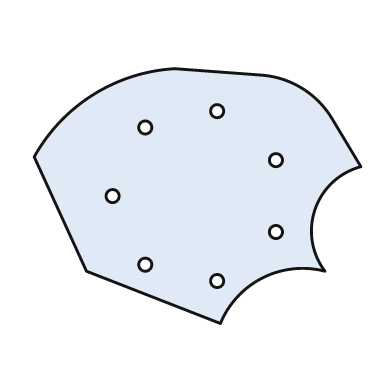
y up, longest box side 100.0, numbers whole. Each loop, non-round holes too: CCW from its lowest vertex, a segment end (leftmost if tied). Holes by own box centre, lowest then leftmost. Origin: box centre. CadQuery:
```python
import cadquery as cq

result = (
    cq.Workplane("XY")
    .moveTo(7.0, -39.0)
    .threePointArc((20.0, -25.0), (39.0, -23.0))
    .threePointArc((36.0, -4.0), (50.0, 9.0))
    .lineTo(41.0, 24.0)
    .threePointArc((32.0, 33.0), (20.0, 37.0))
    .lineTo(-7.0, 39.0)
    .threePointArc((-32.0, 31.0), (-50.0, 12.0))
    .lineTo(-34.0, -23.0)
    .close()
    .moveTo(6.0, -26.0)
    .circle(2.0)
    .moveTo(-16.0, -21.0)
    .circle(2.0)
    .moveTo(24.0, -11.0)
    .circle(2.0)
    .moveTo(-26.0, 0.0)
    .circle(2.0)
    .moveTo(24.0, 11.0)
    .circle(2.0)
    .moveTo(-16.0, 21.0)
    .circle(2.0)
    .moveTo(6.0, 26.0)
    .circle(2.0)
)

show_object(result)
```